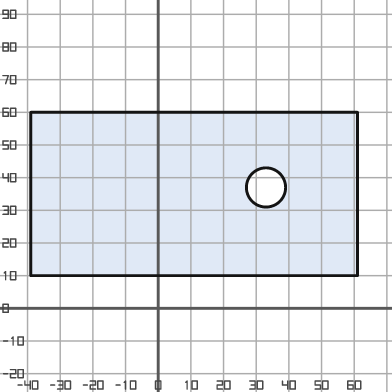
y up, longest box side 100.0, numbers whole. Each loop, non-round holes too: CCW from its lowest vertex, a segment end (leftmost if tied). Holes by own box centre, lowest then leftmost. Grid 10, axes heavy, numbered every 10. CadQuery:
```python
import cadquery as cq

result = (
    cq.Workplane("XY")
    .moveTo(-39.0, 10.0)
    .lineTo(61.0, 10.0)
    .lineTo(61.0, 60.0)
    .lineTo(-39.0, 60.0)
    .close()
    .moveTo(33.0, 37.0)
    .circle(6.0)
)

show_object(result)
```